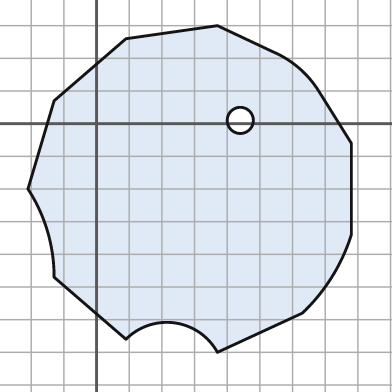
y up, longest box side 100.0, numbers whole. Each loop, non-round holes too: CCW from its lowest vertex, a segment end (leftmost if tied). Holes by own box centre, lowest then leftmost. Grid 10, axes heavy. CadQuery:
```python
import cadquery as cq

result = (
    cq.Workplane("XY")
    .moveTo(37.0, -70.0)
    .lineTo(63.0, -58.0)
    .threePointArc((72.0, -47.0), (78.0, -34.0))
    .lineTo(78.0, -6.0)
    .lineTo(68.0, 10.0)
    .threePointArc((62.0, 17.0), (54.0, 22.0))
    .lineTo(37.0, 30.0)
    .lineTo(9.0, 26.0)
    .lineTo(-13.0, 7.0)
    .lineTo(-21.0, -20.0)
    .threePointArc((-15.0, -33.0), (-13.0, -47.0))
    .lineTo(9.0, -66.0)
    .threePointArc((24.0, -61.0), (37.0, -70.0))
    .close()
    .moveTo(44.0, 1.0)
    .circle(4.0)
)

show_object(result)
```